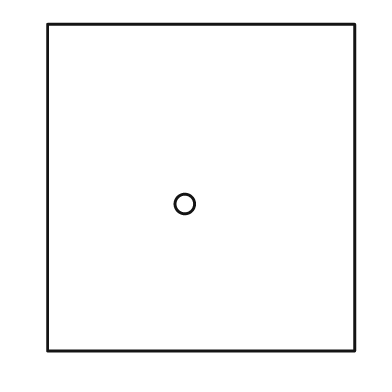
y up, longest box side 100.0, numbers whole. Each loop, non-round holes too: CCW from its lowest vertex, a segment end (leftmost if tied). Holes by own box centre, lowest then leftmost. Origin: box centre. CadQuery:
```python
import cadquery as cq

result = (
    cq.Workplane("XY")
    .moveTo(-47.0, -50.0)
    .lineTo(47.0, -50.0)
    .lineTo(47.0, 50.0)
    .lineTo(-47.0, 50.0)
    .close()
    .moveTo(-5.0, -5.0)
    .circle(3.0)
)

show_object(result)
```